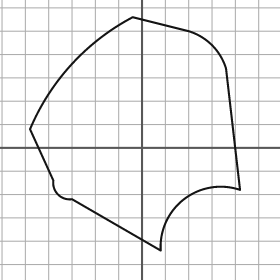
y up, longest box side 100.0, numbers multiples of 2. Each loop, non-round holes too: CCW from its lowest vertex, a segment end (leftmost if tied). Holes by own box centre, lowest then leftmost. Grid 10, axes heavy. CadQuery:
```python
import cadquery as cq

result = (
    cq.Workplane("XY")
    .moveTo(8.0, -44.0)
    .threePointArc((18.0, -22.0), (42.0, -18.0))
    .lineTo(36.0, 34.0)
    .threePointArc((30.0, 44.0), (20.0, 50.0))
    .lineTo(-4.0, 56.0)
    .threePointArc((-30.0, 36.0), (-48.0, 8.0))
    .lineTo(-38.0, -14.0)
    .threePointArc((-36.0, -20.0), (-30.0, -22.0))
    .close()
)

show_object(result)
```